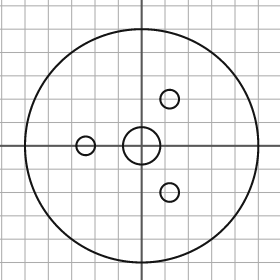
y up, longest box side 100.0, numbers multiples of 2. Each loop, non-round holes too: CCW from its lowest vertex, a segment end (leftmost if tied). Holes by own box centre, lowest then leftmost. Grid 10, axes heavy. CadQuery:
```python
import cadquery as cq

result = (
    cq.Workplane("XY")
    .moveTo(0.0, 0.0)
    .circle(50.0)
    .moveTo(12.0, -20.0)
    .circle(4.0)
    .moveTo(-24.0, 0.0)
    .circle(4.0)
    .moveTo(0.0, 0.0)
    .circle(8.0)
    .moveTo(12.0, 20.0)
    .circle(4.0)
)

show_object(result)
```